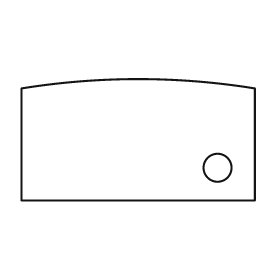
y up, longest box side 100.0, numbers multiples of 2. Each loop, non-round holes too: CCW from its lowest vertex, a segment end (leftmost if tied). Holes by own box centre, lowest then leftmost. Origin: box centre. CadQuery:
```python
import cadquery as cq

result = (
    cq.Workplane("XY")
    .moveTo(-50.0, -26.0)
    .lineTo(50.0, -26.0)
    .lineTo(50.0, 22.0)
    .threePointArc((0.0, 26.0), (-50.0, 22.0))
    .close()
    .moveTo(34.0, -12.0)
    .circle(6.0)
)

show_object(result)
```